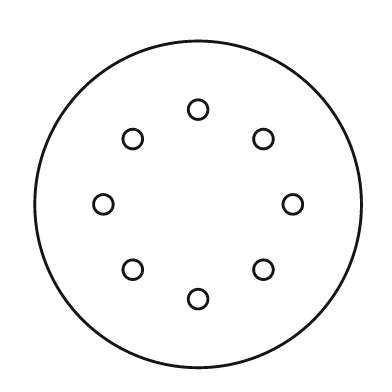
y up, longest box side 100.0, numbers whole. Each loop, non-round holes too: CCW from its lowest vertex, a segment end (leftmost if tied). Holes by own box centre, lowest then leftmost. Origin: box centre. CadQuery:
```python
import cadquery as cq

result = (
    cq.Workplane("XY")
    .moveTo(0.0, 0.0)
    .circle(50.0)
    .moveTo(0.0, -29.0)
    .circle(3.0)
    .moveTo(-20.0, -20.0)
    .circle(3.0)
    .moveTo(20.0, -20.0)
    .circle(3.0)
    .moveTo(-29.0, 0.0)
    .circle(3.0)
    .moveTo(29.0, 0.0)
    .circle(3.0)
    .moveTo(-20.0, 20.0)
    .circle(3.0)
    .moveTo(20.0, 20.0)
    .circle(3.0)
    .moveTo(0.0, 29.0)
    .circle(3.0)
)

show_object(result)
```